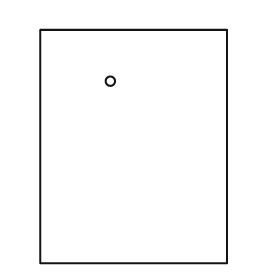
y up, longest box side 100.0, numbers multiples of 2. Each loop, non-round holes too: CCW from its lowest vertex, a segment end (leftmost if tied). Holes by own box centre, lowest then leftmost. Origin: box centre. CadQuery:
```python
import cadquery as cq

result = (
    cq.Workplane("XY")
    .moveTo(-40.0, -50.0)
    .lineTo(40.0, -50.0)
    .lineTo(40.0, 50.0)
    .lineTo(-40.0, 50.0)
    .close()
    .moveTo(-10.0, 28.0)
    .circle(2.0)
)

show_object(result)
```